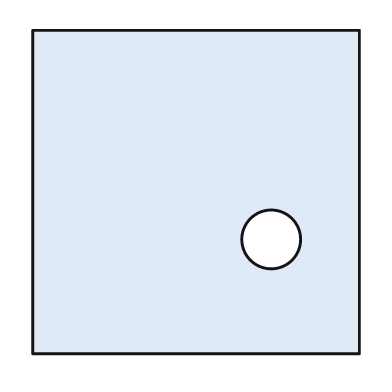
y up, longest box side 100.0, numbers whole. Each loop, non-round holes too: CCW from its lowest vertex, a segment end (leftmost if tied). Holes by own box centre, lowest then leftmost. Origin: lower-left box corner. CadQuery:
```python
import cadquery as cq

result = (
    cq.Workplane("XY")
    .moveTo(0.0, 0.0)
    .lineTo(100.0, 0.0)
    .lineTo(100.0, 99.0)
    .lineTo(0.0, 99.0)
    .close()
    .moveTo(73.0, 35.0)
    .circle(9.0)
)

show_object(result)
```